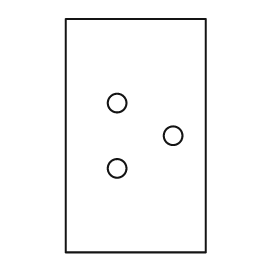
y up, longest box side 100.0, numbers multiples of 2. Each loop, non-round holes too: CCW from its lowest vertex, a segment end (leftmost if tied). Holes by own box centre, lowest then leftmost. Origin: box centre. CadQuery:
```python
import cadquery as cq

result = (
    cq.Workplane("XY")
    .moveTo(-30.0, -50.0)
    .lineTo(30.0, -50.0)
    .lineTo(30.0, 50.0)
    .lineTo(-30.0, 50.0)
    .close()
    .moveTo(-8.0, -14.0)
    .circle(4.0)
    .moveTo(16.0, 0.0)
    .circle(4.0)
    .moveTo(-8.0, 14.0)
    .circle(4.0)
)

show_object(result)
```